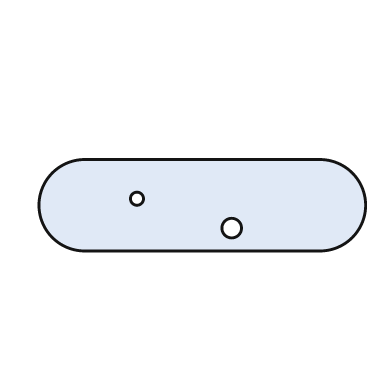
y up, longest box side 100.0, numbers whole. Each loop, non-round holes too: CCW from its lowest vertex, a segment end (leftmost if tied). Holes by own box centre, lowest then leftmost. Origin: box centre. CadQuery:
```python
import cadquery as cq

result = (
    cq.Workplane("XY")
    .moveTo(-36.0, -14.0)
    .lineTo(36.0, -14.0)
    .threePointArc((50.0, 0.0), (36.0, 14.0))
    .lineTo(-36.0, 14.0)
    .threePointArc((-50.0, 0.0), (-36.0, -14.0))
    .close()
    .moveTo(9.0, -7.0)
    .circle(3.0)
    .moveTo(-20.0, 2.0)
    .circle(2.0)
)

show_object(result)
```